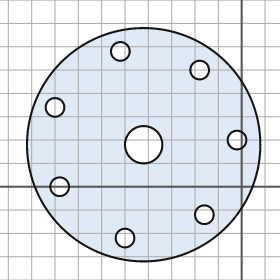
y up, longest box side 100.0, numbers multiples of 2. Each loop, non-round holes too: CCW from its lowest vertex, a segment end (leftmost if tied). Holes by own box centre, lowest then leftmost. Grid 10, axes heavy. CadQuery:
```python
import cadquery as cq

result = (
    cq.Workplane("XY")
    .moveTo(-42.0, 18.0)
    .circle(50.0)
    .moveTo(-50.0, -22.0)
    .circle(4.0)
    .moveTo(-16.0, -12.0)
    .circle(4.0)
    .moveTo(-78.0, 0.0)
    .circle(4.0)
    .moveTo(-42.0, 18.0)
    .circle(8.0)
    .moveTo(-2.0, 20.0)
    .circle(4.0)
    .moveTo(-80.0, 34.0)
    .circle(4.0)
    .moveTo(-18.0, 50.0)
    .circle(4.0)
    .moveTo(-52.0, 58.0)
    .circle(4.0)
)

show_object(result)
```